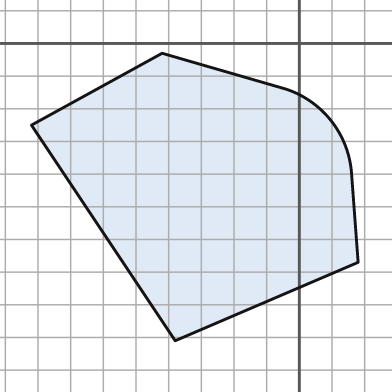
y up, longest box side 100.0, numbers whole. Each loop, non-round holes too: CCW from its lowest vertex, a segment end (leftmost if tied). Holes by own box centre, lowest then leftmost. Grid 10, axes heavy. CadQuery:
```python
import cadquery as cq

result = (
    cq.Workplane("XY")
    .moveTo(-38.0, -91.0)
    .lineTo(18.0, -67.0)
    .lineTo(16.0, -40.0)
    .threePointArc((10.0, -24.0), (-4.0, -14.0))
    .lineTo(-42.0, -3.0)
    .lineTo(-82.0, -25.0)
    .close()
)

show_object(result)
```